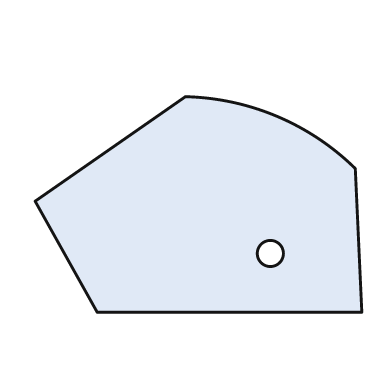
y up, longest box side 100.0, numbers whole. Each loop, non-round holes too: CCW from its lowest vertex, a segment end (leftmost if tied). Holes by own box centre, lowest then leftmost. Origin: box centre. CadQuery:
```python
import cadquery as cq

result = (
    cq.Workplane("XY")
    .moveTo(-31.0, -33.0)
    .lineTo(50.0, -33.0)
    .lineTo(48.0, 11.0)
    .threePointArc((24.0, 27.0), (-4.0, 33.0))
    .lineTo(-50.0, 1.0)
    .close()
    .moveTo(22.0, -15.0)
    .circle(4.0)
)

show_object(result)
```